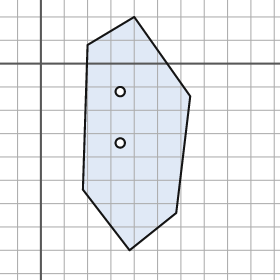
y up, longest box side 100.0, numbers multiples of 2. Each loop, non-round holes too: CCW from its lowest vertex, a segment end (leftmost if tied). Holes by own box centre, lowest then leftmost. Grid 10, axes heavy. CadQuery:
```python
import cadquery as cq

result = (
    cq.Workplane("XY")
    .moveTo(38.0, -80.0)
    .lineTo(58.0, -64.0)
    .lineTo(64.0, -14.0)
    .lineTo(40.0, 20.0)
    .lineTo(20.0, 8.0)
    .lineTo(18.0, -54.0)
    .close()
    .moveTo(34.0, -34.0)
    .circle(2.0)
    .moveTo(34.0, -12.0)
    .circle(2.0)
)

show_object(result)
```